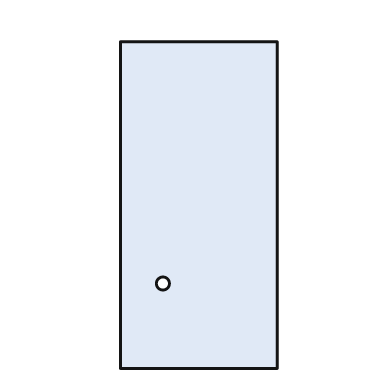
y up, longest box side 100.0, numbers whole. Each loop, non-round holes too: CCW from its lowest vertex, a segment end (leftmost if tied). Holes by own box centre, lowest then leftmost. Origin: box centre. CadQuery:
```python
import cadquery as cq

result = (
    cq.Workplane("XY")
    .moveTo(-24.0, -50.0)
    .lineTo(24.0, -50.0)
    .lineTo(24.0, 50.0)
    .lineTo(-24.0, 50.0)
    .close()
    .moveTo(-11.0, -24.0)
    .circle(2.0)
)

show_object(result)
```